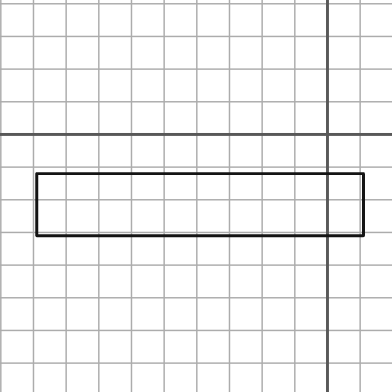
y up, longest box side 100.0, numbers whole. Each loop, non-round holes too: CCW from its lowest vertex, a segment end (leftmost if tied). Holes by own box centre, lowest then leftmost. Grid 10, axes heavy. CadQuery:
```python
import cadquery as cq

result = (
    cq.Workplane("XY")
    .moveTo(-89.0, -31.0)
    .lineTo(11.0, -31.0)
    .lineTo(11.0, -12.0)
    .lineTo(-89.0, -12.0)
    .close()
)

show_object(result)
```